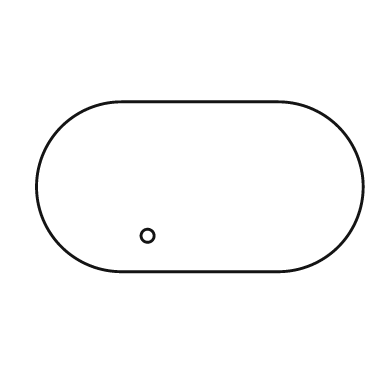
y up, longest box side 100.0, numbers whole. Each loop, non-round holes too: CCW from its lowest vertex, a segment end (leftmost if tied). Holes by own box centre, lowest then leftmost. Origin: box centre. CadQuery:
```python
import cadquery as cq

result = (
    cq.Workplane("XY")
    .moveTo(-24.0, -26.0)
    .lineTo(24.0, -26.0)
    .threePointArc((50.0, 0.0), (24.0, 26.0))
    .lineTo(-24.0, 26.0)
    .threePointArc((-50.0, 0.0), (-24.0, -26.0))
    .close()
    .moveTo(-16.0, -15.0)
    .circle(2.0)
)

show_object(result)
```